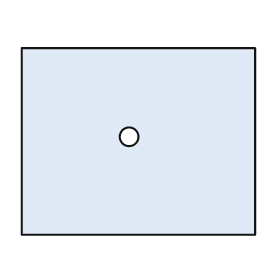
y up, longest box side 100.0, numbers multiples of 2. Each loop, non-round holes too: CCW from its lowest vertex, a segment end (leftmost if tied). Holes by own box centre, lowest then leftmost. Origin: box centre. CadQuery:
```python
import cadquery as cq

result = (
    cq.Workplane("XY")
    .moveTo(-50.0, -40.0)
    .lineTo(50.0, -40.0)
    .lineTo(50.0, 40.0)
    .lineTo(-50.0, 40.0)
    .close()
    .moveTo(-4.0, 2.0)
    .circle(4.0)
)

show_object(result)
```